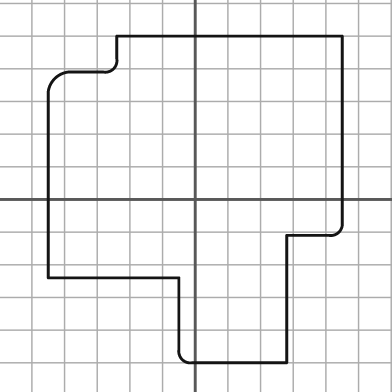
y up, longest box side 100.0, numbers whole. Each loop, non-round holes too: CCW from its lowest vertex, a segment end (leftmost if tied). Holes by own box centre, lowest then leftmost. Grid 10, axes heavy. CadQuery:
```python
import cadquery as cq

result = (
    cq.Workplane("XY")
    .moveTo(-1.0, -50.0)
    .lineTo(28.0, -50.0)
    .lineTo(28.0, -11.0)
    .lineTo(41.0, -11.0)
    .threePointArc((44.0, -10.0), (45.0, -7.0))
    .lineTo(45.0, 50.0)
    .lineTo(-24.0, 50.0)
    .lineTo(-24.0, 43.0)
    .threePointArc((-25.0, 40.0), (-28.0, 39.0))
    .lineTo(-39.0, 39.0)
    .threePointArc((-43.0, 37.0), (-45.0, 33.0))
    .lineTo(-45.0, -24.0)
    .lineTo(-5.0, -24.0)
    .lineTo(-5.0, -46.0)
    .threePointArc((-4.0, -49.0), (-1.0, -50.0))
    .close()
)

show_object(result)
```